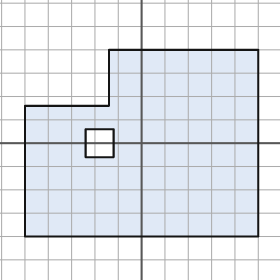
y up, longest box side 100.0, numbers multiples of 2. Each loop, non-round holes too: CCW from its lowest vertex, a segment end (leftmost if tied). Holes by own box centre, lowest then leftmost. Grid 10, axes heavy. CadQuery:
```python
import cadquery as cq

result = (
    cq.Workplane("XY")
    .moveTo(-50.0, -40.0)
    .lineTo(50.0, -40.0)
    .lineTo(50.0, 40.0)
    .lineTo(-14.0, 40.0)
    .lineTo(-14.0, 16.0)
    .lineTo(-50.0, 16.0)
    .close()
    .moveTo(-24.0, -6.0)
    .lineTo(-12.0, -6.0)
    .lineTo(-12.0, 6.0)
    .lineTo(-24.0, 6.0)
    .close()
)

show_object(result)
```